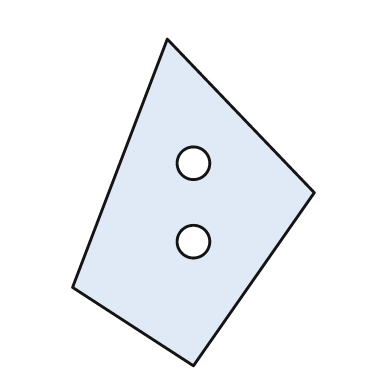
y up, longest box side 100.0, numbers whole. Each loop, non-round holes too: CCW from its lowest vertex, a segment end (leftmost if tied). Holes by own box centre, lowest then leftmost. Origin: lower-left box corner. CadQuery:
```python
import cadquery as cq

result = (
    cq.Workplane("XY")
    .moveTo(37.0, 0.0)
    .lineTo(74.0, 53.0)
    .lineTo(29.0, 100.0)
    .lineTo(0.0, 24.0)
    .close()
    .moveTo(37.0, 38.0)
    .circle(5.0)
    .moveTo(37.0, 62.0)
    .circle(5.0)
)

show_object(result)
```